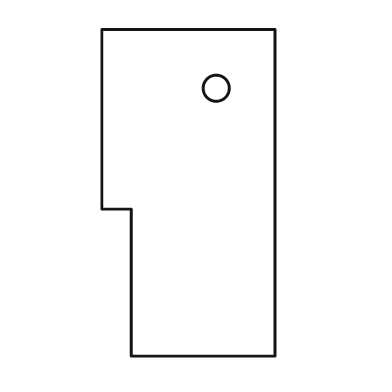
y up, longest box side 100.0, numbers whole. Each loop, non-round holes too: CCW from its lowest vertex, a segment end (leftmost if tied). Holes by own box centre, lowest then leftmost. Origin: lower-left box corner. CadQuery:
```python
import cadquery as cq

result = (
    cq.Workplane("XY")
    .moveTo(9.0, 0.0)
    .lineTo(53.0, 0.0)
    .lineTo(53.0, 100.0)
    .lineTo(0.0, 100.0)
    .lineTo(0.0, 45.0)
    .lineTo(9.0, 45.0)
    .close()
    .moveTo(35.0, 82.0)
    .circle(4.0)
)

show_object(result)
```